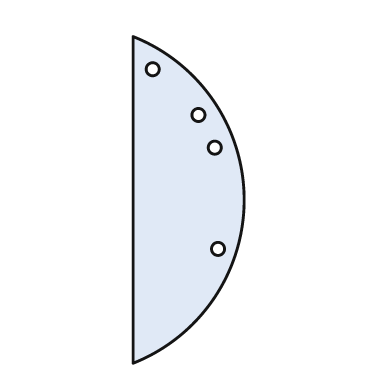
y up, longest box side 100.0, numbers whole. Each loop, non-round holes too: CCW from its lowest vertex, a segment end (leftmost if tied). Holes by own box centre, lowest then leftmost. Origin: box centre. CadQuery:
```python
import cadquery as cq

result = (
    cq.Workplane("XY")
    .moveTo(-17.0, -50.0)
    .threePointArc((17.0, 0.0), (-17.0, 50.0))
    .close()
    .moveTo(9.0, -15.0)
    .circle(2.0)
    .moveTo(8.0, 16.0)
    .circle(2.0)
    .moveTo(3.0, 26.0)
    .circle(2.0)
    .moveTo(-11.0, 40.0)
    .circle(2.0)
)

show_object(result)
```